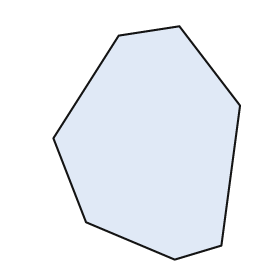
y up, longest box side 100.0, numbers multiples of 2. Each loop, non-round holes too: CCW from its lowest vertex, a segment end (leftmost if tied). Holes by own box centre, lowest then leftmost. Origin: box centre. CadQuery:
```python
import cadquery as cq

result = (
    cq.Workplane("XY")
    .moveTo(12.0, -50.0)
    .lineTo(32.0, -44.0)
    .lineTo(40.0, 16.0)
    .lineTo(14.0, 50.0)
    .lineTo(-12.0, 46.0)
    .lineTo(-40.0, 2.0)
    .lineTo(-26.0, -34.0)
    .close()
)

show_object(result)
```